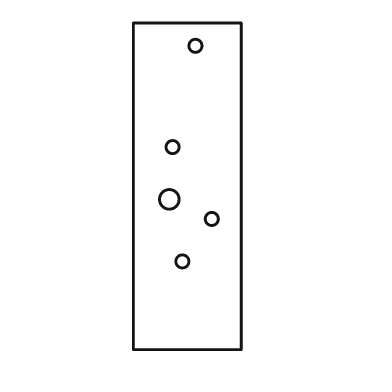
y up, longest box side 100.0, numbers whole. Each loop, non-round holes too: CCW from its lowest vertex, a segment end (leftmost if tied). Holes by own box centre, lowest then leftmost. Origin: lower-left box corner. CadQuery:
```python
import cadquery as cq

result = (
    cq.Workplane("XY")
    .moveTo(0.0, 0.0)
    .lineTo(33.0, 0.0)
    .lineTo(33.0, 100.0)
    .lineTo(0.0, 100.0)
    .close()
    .moveTo(15.0, 27.0)
    .circle(2.0)
    .moveTo(24.0, 40.0)
    .circle(2.0)
    .moveTo(11.0, 46.0)
    .circle(3.0)
    .moveTo(12.0, 62.0)
    .circle(2.0)
    .moveTo(19.0, 93.0)
    .circle(2.0)
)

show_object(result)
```